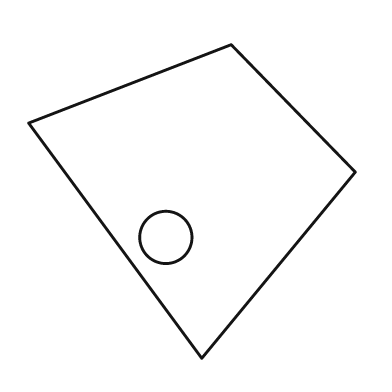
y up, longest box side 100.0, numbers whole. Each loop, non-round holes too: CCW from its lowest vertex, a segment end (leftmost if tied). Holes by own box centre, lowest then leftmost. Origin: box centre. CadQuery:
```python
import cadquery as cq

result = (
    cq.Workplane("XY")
    .moveTo(3.0, -48.0)
    .lineTo(50.0, 9.0)
    .lineTo(12.0, 48.0)
    .lineTo(-50.0, 24.0)
    .close()
    .moveTo(-8.0, -11.0)
    .circle(8.0)
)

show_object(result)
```